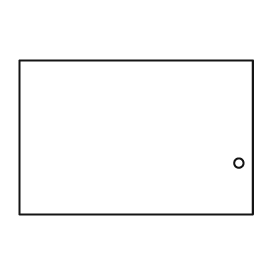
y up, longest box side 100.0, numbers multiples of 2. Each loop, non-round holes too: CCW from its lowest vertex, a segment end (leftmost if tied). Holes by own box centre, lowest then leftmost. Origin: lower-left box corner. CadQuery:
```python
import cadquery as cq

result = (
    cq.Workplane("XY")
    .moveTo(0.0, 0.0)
    .lineTo(100.0, 0.0)
    .lineTo(100.0, 66.0)
    .lineTo(0.0, 66.0)
    .close()
    .moveTo(94.0, 22.0)
    .circle(2.0)
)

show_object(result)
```